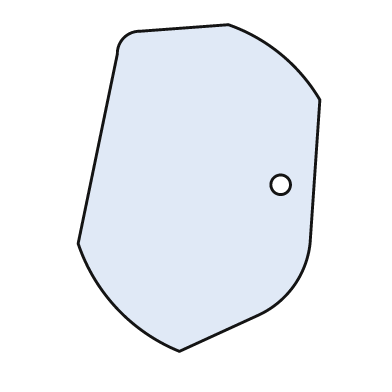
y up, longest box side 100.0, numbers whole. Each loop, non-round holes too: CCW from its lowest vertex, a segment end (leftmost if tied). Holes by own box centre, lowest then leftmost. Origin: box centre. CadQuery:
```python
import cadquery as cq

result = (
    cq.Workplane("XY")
    .moveTo(-6.0, -50.0)
    .lineTo(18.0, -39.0)
    .threePointArc((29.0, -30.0), (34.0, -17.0))
    .lineTo(37.0, 27.0)
    .threePointArc((25.0, 41.0), (9.0, 50.0))
    .lineTo(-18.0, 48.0)
    .threePointArc((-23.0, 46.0), (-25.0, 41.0))
    .lineTo(-37.0, -17.0)
    .threePointArc((-25.0, -37.0), (-6.0, -50.0))
    .close()
    .moveTo(25.0, 1.0)
    .circle(3.0)
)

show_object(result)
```